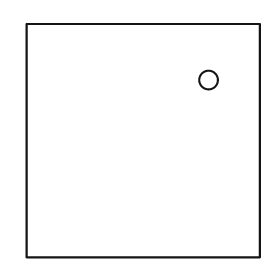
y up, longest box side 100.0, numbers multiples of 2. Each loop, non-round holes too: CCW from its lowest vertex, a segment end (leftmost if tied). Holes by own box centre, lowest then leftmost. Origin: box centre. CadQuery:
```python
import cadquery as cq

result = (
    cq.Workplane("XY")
    .moveTo(-50.0, -50.0)
    .lineTo(50.0, -50.0)
    .lineTo(50.0, 50.0)
    .lineTo(-50.0, 50.0)
    .close()
    .moveTo(28.0, 26.0)
    .circle(4.0)
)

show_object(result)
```